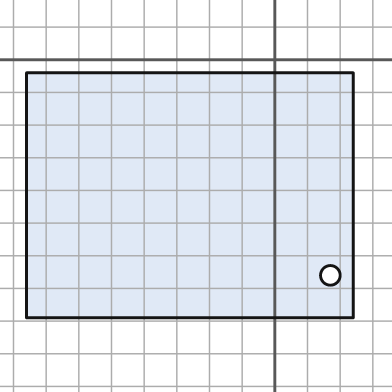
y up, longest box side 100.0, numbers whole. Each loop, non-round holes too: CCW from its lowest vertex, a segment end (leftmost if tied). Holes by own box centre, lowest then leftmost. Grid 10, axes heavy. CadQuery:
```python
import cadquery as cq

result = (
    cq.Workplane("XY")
    .moveTo(-76.0, -79.0)
    .lineTo(24.0, -79.0)
    .lineTo(24.0, -4.0)
    .lineTo(-76.0, -4.0)
    .close()
    .moveTo(17.0, -66.0)
    .circle(3.0)
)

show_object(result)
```